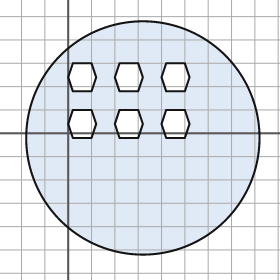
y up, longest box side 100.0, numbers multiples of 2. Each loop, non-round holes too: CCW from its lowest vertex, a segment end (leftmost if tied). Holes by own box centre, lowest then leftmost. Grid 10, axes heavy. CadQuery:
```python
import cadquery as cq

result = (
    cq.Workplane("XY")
    .moveTo(32.0, -2.0)
    .circle(50.0)
    .moveTo(2.0, -2.0)
    .lineTo(10.0, -2.0)
    .lineTo(12.0, 4.0)
    .lineTo(10.0, 10.0)
    .lineTo(2.0, 10.0)
    .lineTo(0.0, 4.0)
    .close()
    .moveTo(22.0, -2.0)
    .lineTo(30.0, -2.0)
    .lineTo(32.0, 4.0)
    .lineTo(30.0, 10.0)
    .lineTo(22.0, 10.0)
    .lineTo(20.0, 4.0)
    .close()
    .moveTo(42.0, -2.0)
    .lineTo(50.0, -2.0)
    .lineTo(52.0, 4.0)
    .lineTo(50.0, 10.0)
    .lineTo(42.0, 10.0)
    .lineTo(40.0, 4.0)
    .close()
    .moveTo(2.0, 18.0)
    .lineTo(10.0, 18.0)
    .lineTo(12.0, 24.0)
    .lineTo(10.0, 30.0)
    .lineTo(2.0, 30.0)
    .lineTo(0.0, 24.0)
    .close()
    .moveTo(22.0, 18.0)
    .lineTo(30.0, 18.0)
    .lineTo(32.0, 24.0)
    .lineTo(30.0, 30.0)
    .lineTo(22.0, 30.0)
    .lineTo(20.0, 24.0)
    .close()
    .moveTo(42.0, 18.0)
    .lineTo(50.0, 18.0)
    .lineTo(52.0, 24.0)
    .lineTo(50.0, 30.0)
    .lineTo(42.0, 30.0)
    .lineTo(40.0, 24.0)
    .close()
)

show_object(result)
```